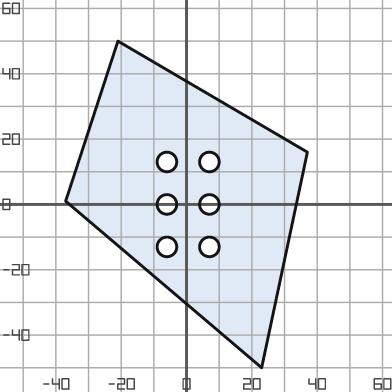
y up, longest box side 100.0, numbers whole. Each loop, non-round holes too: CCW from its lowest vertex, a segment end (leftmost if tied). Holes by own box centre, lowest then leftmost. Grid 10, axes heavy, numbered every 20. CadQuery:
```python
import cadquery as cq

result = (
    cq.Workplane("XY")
    .moveTo(23.0, -50.0)
    .lineTo(37.0, 16.0)
    .lineTo(-21.0, 50.0)
    .lineTo(-37.0, 1.0)
    .close()
    .moveTo(-6.0, -13.0)
    .circle(3.0)
    .moveTo(7.0, -13.0)
    .circle(3.0)
    .moveTo(-6.0, 0.0)
    .circle(3.0)
    .moveTo(7.0, 0.0)
    .circle(3.0)
    .moveTo(-6.0, 13.0)
    .circle(3.0)
    .moveTo(7.0, 13.0)
    .circle(3.0)
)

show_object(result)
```